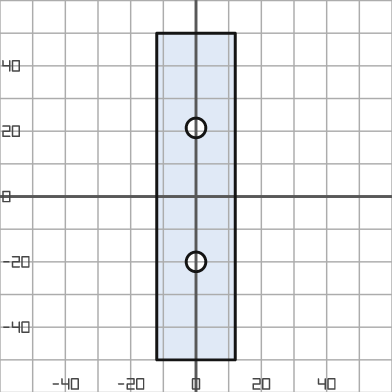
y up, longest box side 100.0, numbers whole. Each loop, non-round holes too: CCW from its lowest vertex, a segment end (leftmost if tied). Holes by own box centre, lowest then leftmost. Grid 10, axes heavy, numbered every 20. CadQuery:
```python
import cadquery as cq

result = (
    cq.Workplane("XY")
    .moveTo(-12.0, -50.0)
    .lineTo(12.0, -50.0)
    .lineTo(12.0, 50.0)
    .lineTo(-12.0, 50.0)
    .close()
    .moveTo(0.0, -20.0)
    .circle(3.0)
    .moveTo(0.0, 21.0)
    .circle(3.0)
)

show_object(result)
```